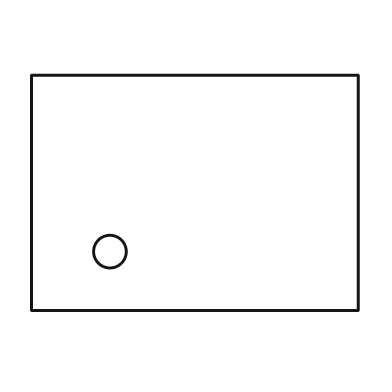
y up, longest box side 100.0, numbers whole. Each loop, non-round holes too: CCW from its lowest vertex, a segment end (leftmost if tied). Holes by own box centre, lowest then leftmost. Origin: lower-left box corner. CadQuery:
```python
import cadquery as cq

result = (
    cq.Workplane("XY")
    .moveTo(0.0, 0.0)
    .lineTo(100.0, 0.0)
    .lineTo(100.0, 72.0)
    .lineTo(0.0, 72.0)
    .close()
    .moveTo(24.0, 18.0)
    .circle(5.0)
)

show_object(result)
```